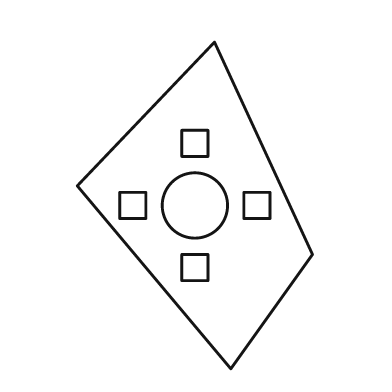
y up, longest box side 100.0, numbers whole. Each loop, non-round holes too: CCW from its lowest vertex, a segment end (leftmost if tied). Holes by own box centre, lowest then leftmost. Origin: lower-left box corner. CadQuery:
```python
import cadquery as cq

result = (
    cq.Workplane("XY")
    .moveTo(47.0, 0.0)
    .lineTo(72.0, 35.0)
    .lineTo(42.0, 100.0)
    .lineTo(0.0, 56.0)
    .close()
    .moveTo(32.0, 27.0)
    .lineTo(40.0, 27.0)
    .lineTo(40.0, 35.0)
    .lineTo(32.0, 35.0)
    .close()
    .moveTo(13.0, 46.0)
    .lineTo(21.0, 46.0)
    .lineTo(21.0, 54.0)
    .lineTo(13.0, 54.0)
    .close()
    .moveTo(36.0, 50.0)
    .circle(10.0)
    .moveTo(51.0, 46.0)
    .lineTo(59.0, 46.0)
    .lineTo(59.0, 54.0)
    .lineTo(51.0, 54.0)
    .close()
    .moveTo(32.0, 65.0)
    .lineTo(40.0, 65.0)
    .lineTo(40.0, 73.0)
    .lineTo(32.0, 73.0)
    .close()
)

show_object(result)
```